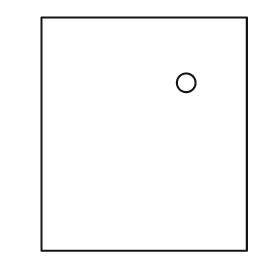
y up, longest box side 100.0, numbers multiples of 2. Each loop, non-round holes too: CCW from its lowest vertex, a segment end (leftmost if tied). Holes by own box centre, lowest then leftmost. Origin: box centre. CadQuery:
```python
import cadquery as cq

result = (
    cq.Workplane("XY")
    .moveTo(-44.0, -50.0)
    .lineTo(44.0, -50.0)
    .lineTo(44.0, 50.0)
    .lineTo(-44.0, 50.0)
    .close()
    .moveTo(18.0, 22.0)
    .circle(4.0)
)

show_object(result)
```